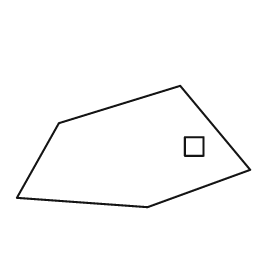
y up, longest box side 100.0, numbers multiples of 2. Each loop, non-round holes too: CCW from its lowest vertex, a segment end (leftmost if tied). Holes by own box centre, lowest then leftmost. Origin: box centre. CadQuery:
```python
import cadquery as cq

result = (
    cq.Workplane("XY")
    .moveTo(6.0, -26.0)
    .lineTo(50.0, -10.0)
    .lineTo(20.0, 26.0)
    .lineTo(-32.0, 10.0)
    .lineTo(-50.0, -22.0)
    .close()
    .moveTo(22.0, -4.0)
    .lineTo(30.0, -4.0)
    .lineTo(30.0, 4.0)
    .lineTo(22.0, 4.0)
    .close()
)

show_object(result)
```